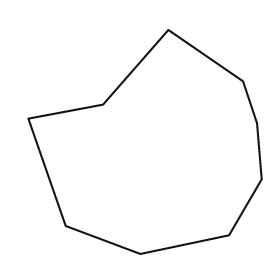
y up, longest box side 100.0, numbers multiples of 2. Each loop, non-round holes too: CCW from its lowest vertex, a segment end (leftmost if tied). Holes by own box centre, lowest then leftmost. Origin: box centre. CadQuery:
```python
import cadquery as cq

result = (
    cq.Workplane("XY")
    .moveTo(-2.0, -48.0)
    .lineTo(36.0, -40.0)
    .lineTo(50.0, -16.0)
    .lineTo(48.0, 8.0)
    .lineTo(42.0, 26.0)
    .lineTo(10.0, 48.0)
    .lineTo(-18.0, 16.0)
    .lineTo(-50.0, 10.0)
    .lineTo(-34.0, -36.0)
    .close()
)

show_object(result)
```